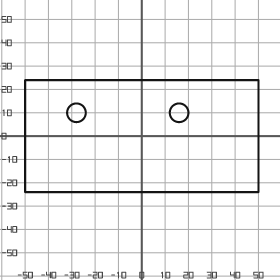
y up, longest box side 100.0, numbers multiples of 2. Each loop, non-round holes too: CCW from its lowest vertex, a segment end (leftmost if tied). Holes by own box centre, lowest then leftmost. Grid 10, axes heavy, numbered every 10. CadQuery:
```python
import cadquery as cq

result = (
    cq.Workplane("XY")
    .moveTo(-50.0, -24.0)
    .lineTo(50.0, -24.0)
    .lineTo(50.0, 24.0)
    .lineTo(-50.0, 24.0)
    .close()
    .moveTo(-28.0, 10.0)
    .circle(4.0)
    .moveTo(16.0, 10.0)
    .circle(4.0)
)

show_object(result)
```